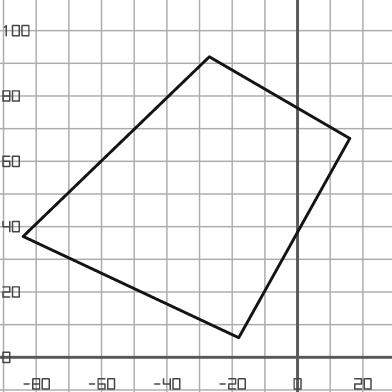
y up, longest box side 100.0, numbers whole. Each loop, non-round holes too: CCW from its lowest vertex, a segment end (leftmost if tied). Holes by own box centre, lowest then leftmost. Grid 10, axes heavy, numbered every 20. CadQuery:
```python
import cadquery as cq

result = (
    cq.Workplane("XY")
    .moveTo(-18.0, 6.0)
    .lineTo(16.0, 67.0)
    .lineTo(-27.0, 92.0)
    .lineTo(-84.0, 37.0)
    .close()
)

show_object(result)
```